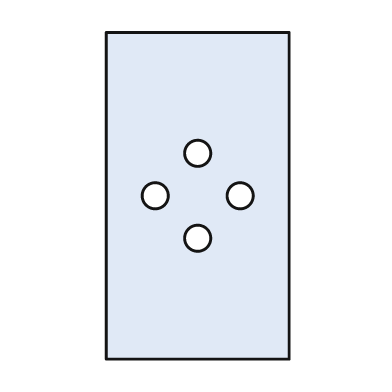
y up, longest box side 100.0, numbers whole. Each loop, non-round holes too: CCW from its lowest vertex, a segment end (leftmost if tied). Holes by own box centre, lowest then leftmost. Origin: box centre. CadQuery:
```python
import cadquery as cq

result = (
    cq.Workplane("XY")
    .moveTo(-28.0, -50.0)
    .lineTo(28.0, -50.0)
    .lineTo(28.0, 50.0)
    .lineTo(-28.0, 50.0)
    .close()
    .moveTo(0.0, -13.0)
    .circle(4.0)
    .moveTo(-13.0, 0.0)
    .circle(4.0)
    .moveTo(13.0, 0.0)
    .circle(4.0)
    .moveTo(0.0, 13.0)
    .circle(4.0)
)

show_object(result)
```